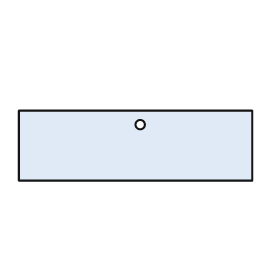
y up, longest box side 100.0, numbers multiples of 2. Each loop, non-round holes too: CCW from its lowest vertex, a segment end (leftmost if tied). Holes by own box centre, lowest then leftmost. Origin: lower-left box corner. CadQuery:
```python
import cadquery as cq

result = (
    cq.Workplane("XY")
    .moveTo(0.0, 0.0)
    .lineTo(100.0, 0.0)
    .lineTo(100.0, 30.0)
    .lineTo(0.0, 30.0)
    .close()
    .moveTo(52.0, 24.0)
    .circle(2.0)
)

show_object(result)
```